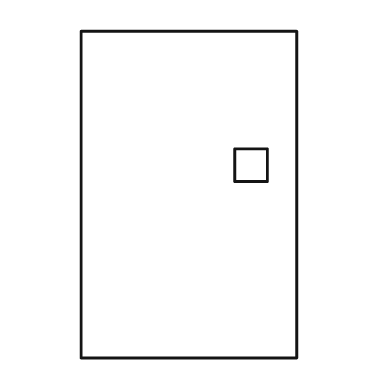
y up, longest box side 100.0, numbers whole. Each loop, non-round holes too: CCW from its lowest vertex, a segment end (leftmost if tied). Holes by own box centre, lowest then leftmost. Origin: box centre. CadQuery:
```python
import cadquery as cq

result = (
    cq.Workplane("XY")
    .moveTo(-33.0, -50.0)
    .lineTo(33.0, -50.0)
    .lineTo(33.0, 50.0)
    .lineTo(-33.0, 50.0)
    .close()
    .moveTo(14.0, 4.0)
    .lineTo(24.0, 4.0)
    .lineTo(24.0, 14.0)
    .lineTo(14.0, 14.0)
    .close()
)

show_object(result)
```